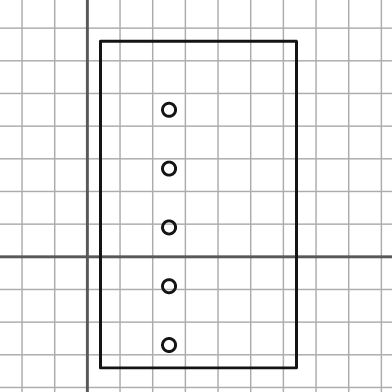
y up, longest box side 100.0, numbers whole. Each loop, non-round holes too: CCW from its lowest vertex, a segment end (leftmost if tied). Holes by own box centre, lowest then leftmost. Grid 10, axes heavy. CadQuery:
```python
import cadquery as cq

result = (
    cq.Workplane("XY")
    .moveTo(4.0, -34.0)
    .lineTo(64.0, -34.0)
    .lineTo(64.0, 66.0)
    .lineTo(4.0, 66.0)
    .close()
    .moveTo(25.0, -27.0)
    .circle(2.0)
    .moveTo(25.0, -9.0)
    .circle(2.0)
    .moveTo(25.0, 9.0)
    .circle(2.0)
    .moveTo(25.0, 27.0)
    .circle(2.0)
    .moveTo(25.0, 45.0)
    .circle(2.0)
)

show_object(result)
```